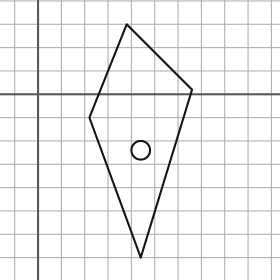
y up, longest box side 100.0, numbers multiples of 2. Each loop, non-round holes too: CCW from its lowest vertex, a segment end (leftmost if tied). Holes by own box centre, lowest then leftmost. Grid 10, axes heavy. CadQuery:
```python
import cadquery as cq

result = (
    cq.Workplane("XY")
    .moveTo(44.0, -70.0)
    .lineTo(66.0, 2.0)
    .lineTo(38.0, 30.0)
    .lineTo(22.0, -10.0)
    .close()
    .moveTo(44.0, -24.0)
    .circle(4.0)
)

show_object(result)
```